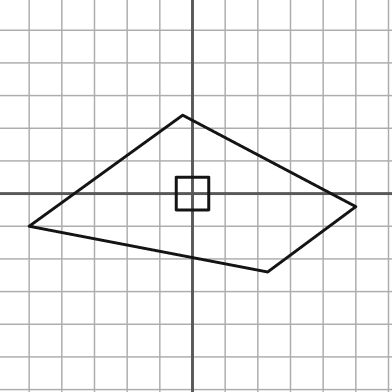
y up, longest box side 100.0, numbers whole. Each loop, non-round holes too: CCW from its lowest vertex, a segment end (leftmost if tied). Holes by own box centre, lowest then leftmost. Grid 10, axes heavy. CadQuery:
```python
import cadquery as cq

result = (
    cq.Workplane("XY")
    .moveTo(23.0, -24.0)
    .lineTo(50.0, -4.0)
    .lineTo(-3.0, 24.0)
    .lineTo(-50.0, -10.0)
    .close()
    .moveTo(-5.0, -5.0)
    .lineTo(5.0, -5.0)
    .lineTo(5.0, 5.0)
    .lineTo(-5.0, 5.0)
    .close()
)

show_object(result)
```